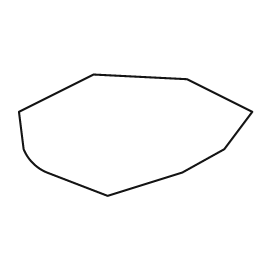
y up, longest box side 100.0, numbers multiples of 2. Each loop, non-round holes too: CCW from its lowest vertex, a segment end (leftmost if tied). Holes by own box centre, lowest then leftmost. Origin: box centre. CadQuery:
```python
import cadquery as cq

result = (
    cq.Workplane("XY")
    .moveTo(-12.0, -26.0)
    .lineTo(20.0, -16.0)
    .lineTo(38.0, -6.0)
    .lineTo(50.0, 10.0)
    .lineTo(22.0, 24.0)
    .lineTo(-18.0, 26.0)
    .lineTo(-50.0, 10.0)
    .lineTo(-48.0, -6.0)
    .threePointArc((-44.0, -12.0), (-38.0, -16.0))
    .close()
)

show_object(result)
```